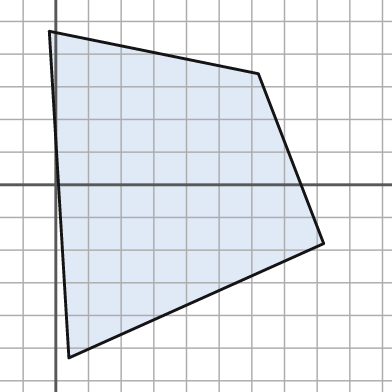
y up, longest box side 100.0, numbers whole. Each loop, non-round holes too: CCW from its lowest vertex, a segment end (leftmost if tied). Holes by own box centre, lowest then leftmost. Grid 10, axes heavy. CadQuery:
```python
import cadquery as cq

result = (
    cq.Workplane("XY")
    .moveTo(4.0, -53.0)
    .lineTo(82.0, -18.0)
    .lineTo(62.0, 34.0)
    .lineTo(-2.0, 47.0)
    .close()
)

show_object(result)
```